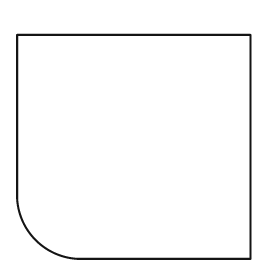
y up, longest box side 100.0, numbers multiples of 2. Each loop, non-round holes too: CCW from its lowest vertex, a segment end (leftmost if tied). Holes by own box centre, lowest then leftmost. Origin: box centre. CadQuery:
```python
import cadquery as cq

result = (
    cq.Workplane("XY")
    .moveTo(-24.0, -48.0)
    .lineTo(50.0, -48.0)
    .lineTo(50.0, 48.0)
    .lineTo(-50.0, 48.0)
    .lineTo(-50.0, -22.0)
    .threePointArc((-42.0, -40.0), (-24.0, -48.0))
    .close()
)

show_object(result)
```